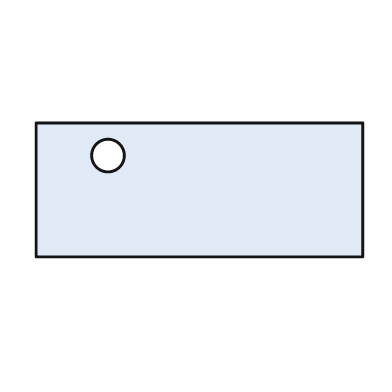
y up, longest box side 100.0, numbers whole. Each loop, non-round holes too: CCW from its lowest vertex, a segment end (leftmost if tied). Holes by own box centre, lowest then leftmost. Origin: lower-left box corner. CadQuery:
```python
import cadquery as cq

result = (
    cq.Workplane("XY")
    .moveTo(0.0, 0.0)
    .lineTo(100.0, 0.0)
    .lineTo(100.0, 41.0)
    .lineTo(0.0, 41.0)
    .close()
    .moveTo(22.0, 31.0)
    .circle(5.0)
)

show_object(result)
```